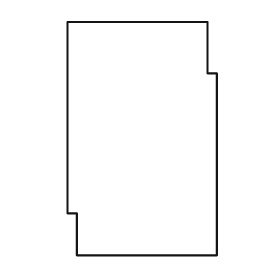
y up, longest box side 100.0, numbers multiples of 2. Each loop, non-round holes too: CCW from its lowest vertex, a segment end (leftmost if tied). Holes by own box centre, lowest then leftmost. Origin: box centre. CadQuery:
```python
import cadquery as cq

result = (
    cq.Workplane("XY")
    .moveTo(-28.0, -50.0)
    .lineTo(32.0, -50.0)
    .lineTo(32.0, 28.0)
    .lineTo(28.0, 28.0)
    .lineTo(28.0, 50.0)
    .lineTo(-32.0, 50.0)
    .lineTo(-32.0, -32.0)
    .lineTo(-28.0, -32.0)
    .close()
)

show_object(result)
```